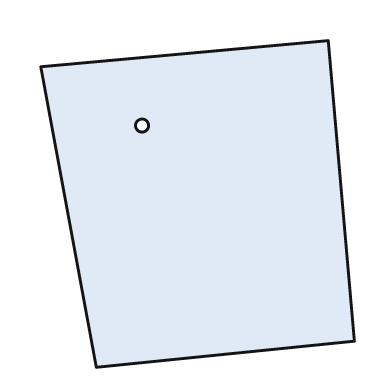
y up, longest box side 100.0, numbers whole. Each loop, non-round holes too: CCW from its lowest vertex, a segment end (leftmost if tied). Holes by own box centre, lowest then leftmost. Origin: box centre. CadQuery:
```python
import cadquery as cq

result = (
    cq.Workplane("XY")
    .moveTo(-31.0, -50.0)
    .lineTo(48.0, -42.0)
    .lineTo(40.0, 50.0)
    .lineTo(-48.0, 42.0)
    .close()
    .moveTo(-17.0, 24.0)
    .circle(2.0)
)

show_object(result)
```